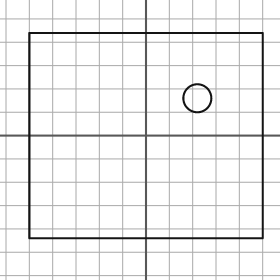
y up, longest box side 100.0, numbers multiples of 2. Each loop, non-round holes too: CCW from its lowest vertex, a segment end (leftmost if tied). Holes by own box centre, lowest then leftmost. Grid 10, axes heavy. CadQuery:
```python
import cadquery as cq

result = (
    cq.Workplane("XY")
    .moveTo(-50.0, -44.0)
    .lineTo(50.0, -44.0)
    .lineTo(50.0, 44.0)
    .lineTo(-50.0, 44.0)
    .close()
    .moveTo(22.0, 16.0)
    .circle(6.0)
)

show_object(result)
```